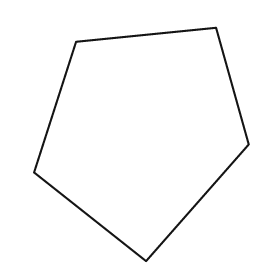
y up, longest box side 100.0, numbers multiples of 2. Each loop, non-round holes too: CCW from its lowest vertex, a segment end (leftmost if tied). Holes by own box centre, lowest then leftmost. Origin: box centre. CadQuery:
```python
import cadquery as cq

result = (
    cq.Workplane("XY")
    .moveTo(2.0, -50.0)
    .lineTo(46.0, 0.0)
    .lineTo(32.0, 50.0)
    .lineTo(-28.0, 44.0)
    .lineTo(-46.0, -12.0)
    .close()
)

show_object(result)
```